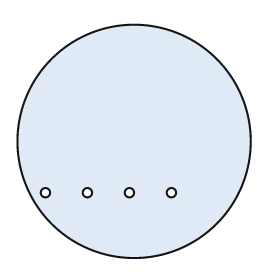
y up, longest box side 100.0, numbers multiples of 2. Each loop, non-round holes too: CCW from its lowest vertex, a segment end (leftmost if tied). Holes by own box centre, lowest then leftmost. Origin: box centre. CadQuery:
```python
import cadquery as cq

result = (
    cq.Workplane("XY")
    .moveTo(0.0, 0.0)
    .circle(50.0)
    .moveTo(-38.0, -22.0)
    .circle(2.0)
    .moveTo(-20.0, -22.0)
    .circle(2.0)
    .moveTo(-2.0, -22.0)
    .circle(2.0)
    .moveTo(16.0, -22.0)
    .circle(2.0)
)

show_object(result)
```